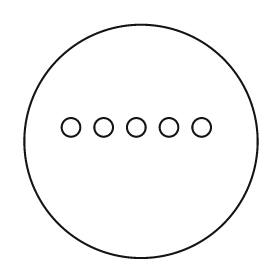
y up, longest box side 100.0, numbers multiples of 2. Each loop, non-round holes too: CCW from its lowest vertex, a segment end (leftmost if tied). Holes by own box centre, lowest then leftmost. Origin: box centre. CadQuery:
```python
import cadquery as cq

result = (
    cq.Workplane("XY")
    .moveTo(0.0, 0.0)
    .circle(50.0)
    .moveTo(-30.0, 6.0)
    .circle(4.0)
    .moveTo(-16.0, 6.0)
    .circle(4.0)
    .moveTo(-2.0, 6.0)
    .circle(4.0)
    .moveTo(12.0, 6.0)
    .circle(4.0)
    .moveTo(26.0, 6.0)
    .circle(4.0)
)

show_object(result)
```